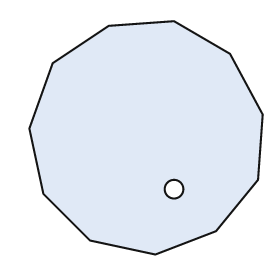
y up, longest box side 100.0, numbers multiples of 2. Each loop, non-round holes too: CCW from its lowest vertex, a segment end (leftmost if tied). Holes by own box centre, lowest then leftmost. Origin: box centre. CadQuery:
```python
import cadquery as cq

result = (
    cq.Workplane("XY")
    .moveTo(4.0, -50.0)
    .lineTo(30.0, -40.0)
    .lineTo(48.0, -18.0)
    .lineTo(50.0, 10.0)
    .lineTo(36.0, 36.0)
    .lineTo(12.0, 50.0)
    .lineTo(-16.0, 48.0)
    .lineTo(-40.0, 32.0)
    .lineTo(-50.0, 4.0)
    .lineTo(-44.0, -24.0)
    .lineTo(-24.0, -44.0)
    .close()
    .moveTo(12.0, -22.0)
    .circle(4.0)
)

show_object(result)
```